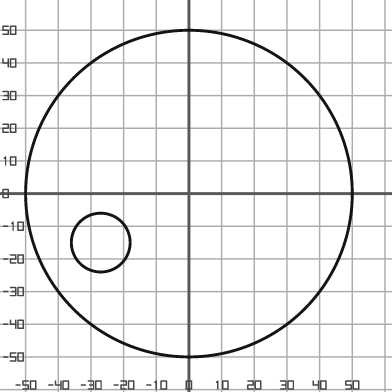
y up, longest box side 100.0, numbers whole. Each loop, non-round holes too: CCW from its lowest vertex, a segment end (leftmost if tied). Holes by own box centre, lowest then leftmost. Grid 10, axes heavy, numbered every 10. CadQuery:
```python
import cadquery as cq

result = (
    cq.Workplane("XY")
    .moveTo(0.0, 0.0)
    .circle(50.0)
    .moveTo(-27.0, -15.0)
    .circle(9.0)
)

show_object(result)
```